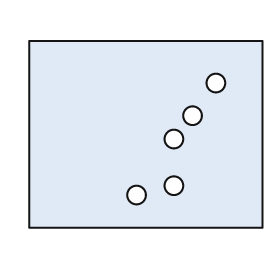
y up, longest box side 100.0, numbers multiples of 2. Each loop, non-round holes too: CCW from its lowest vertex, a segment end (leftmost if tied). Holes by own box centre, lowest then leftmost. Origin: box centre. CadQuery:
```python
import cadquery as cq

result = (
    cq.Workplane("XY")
    .moveTo(-50.0, -40.0)
    .lineTo(50.0, -40.0)
    .lineTo(50.0, 40.0)
    .lineTo(-50.0, 40.0)
    .close()
    .moveTo(-4.0, -26.0)
    .circle(4.0)
    .moveTo(12.0, -22.0)
    .circle(4.0)
    .moveTo(12.0, -2.0)
    .circle(4.0)
    .moveTo(20.0, 8.0)
    .circle(4.0)
    .moveTo(30.0, 22.0)
    .circle(4.0)
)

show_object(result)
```